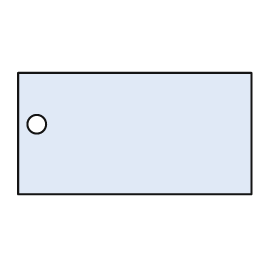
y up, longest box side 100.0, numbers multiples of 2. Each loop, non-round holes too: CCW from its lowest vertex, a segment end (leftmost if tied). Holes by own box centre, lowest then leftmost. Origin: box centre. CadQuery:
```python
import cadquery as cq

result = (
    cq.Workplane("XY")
    .moveTo(-50.0, -26.0)
    .lineTo(50.0, -26.0)
    .lineTo(50.0, 26.0)
    .lineTo(-50.0, 26.0)
    .close()
    .moveTo(-42.0, 4.0)
    .circle(4.0)
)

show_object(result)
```